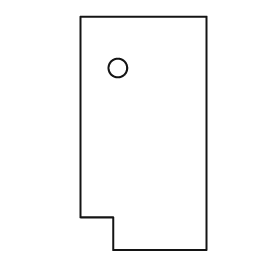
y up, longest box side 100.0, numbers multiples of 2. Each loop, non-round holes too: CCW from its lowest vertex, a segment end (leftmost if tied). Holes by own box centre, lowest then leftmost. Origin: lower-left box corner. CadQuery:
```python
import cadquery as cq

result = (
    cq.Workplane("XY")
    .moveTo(14.0, 0.0)
    .lineTo(54.0, 0.0)
    .lineTo(54.0, 100.0)
    .lineTo(0.0, 100.0)
    .lineTo(0.0, 14.0)
    .lineTo(14.0, 14.0)
    .close()
    .moveTo(16.0, 78.0)
    .circle(4.0)
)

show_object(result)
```